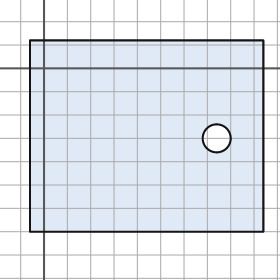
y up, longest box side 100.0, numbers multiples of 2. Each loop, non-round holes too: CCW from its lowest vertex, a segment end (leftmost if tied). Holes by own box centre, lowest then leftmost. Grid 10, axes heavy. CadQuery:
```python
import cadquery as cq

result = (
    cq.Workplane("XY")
    .moveTo(-6.0, -70.0)
    .lineTo(94.0, -70.0)
    .lineTo(94.0, 12.0)
    .lineTo(-6.0, 12.0)
    .close()
    .moveTo(74.0, -30.0)
    .circle(6.0)
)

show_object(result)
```